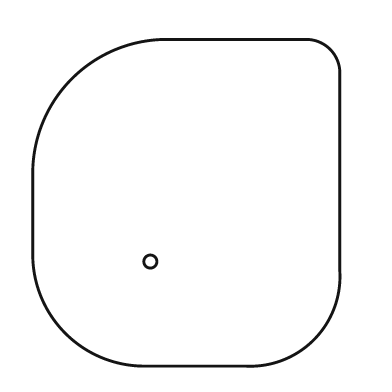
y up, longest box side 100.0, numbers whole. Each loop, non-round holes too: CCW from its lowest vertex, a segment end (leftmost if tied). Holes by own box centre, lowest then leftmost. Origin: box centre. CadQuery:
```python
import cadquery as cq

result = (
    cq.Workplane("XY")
    .moveTo(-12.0, -50.0)
    .lineTo(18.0, -50.0)
    .threePointArc((39.0, -42.0), (47.0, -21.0))
    .lineTo(47.0, 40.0)
    .threePointArc((44.0, 47.0), (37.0, 50.0))
    .lineTo(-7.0, 50.0)
    .threePointArc((-35.0, 38.0), (-47.0, 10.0))
    .lineTo(-47.0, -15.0)
    .threePointArc((-37.0, -40.0), (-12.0, -50.0))
    .close()
    .moveTo(-11.0, -18.0)
    .circle(2.0)
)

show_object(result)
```